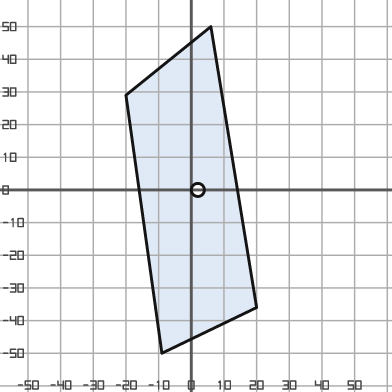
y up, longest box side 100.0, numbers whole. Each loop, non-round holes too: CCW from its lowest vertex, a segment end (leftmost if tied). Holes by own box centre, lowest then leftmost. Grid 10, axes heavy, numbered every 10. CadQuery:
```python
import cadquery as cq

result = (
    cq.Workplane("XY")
    .moveTo(-9.0, -50.0)
    .lineTo(20.0, -36.0)
    .lineTo(6.0, 50.0)
    .lineTo(-20.0, 29.0)
    .close()
    .moveTo(2.0, 0.0)
    .circle(2.0)
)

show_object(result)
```